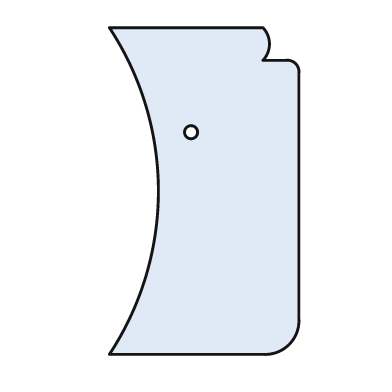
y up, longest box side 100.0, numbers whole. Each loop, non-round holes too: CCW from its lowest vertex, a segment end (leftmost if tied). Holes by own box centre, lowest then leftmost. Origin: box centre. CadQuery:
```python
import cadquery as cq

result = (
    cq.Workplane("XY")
    .moveTo(-29.0, -50.0)
    .lineTo(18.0, -50.0)
    .threePointArc((26.0, -47.0), (29.0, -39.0))
    .lineTo(29.0, 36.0)
    .threePointArc((28.0, 39.0), (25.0, 40.0))
    .lineTo(18.0, 40.0)
    .threePointArc((20.0, 45.0), (18.0, 50.0))
    .lineTo(-29.0, 50.0)
    .threePointArc((-14.0, 0.0), (-29.0, -50.0))
    .close()
    .moveTo(-4.0, 18.0)
    .circle(2.0)
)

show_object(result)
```